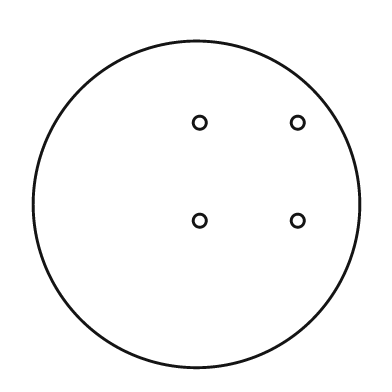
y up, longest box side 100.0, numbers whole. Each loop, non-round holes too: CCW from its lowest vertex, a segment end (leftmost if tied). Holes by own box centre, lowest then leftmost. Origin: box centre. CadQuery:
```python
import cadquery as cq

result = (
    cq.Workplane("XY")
    .moveTo(0.0, 0.0)
    .circle(50.0)
    .moveTo(1.0, -5.0)
    .circle(2.0)
    .moveTo(31.0, -5.0)
    .circle(2.0)
    .moveTo(1.0, 25.0)
    .circle(2.0)
    .moveTo(31.0, 25.0)
    .circle(2.0)
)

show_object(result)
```